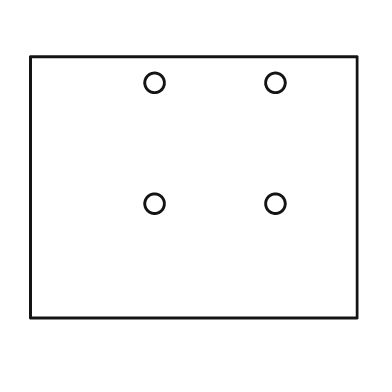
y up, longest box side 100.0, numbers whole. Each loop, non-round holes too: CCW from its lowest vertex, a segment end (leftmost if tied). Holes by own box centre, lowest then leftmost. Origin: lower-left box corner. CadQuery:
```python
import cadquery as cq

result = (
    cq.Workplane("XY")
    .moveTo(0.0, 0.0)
    .lineTo(100.0, 0.0)
    .lineTo(100.0, 80.0)
    .lineTo(0.0, 80.0)
    .close()
    .moveTo(38.0, 35.0)
    .circle(3.0)
    .moveTo(75.0, 35.0)
    .circle(3.0)
    .moveTo(38.0, 72.0)
    .circle(3.0)
    .moveTo(75.0, 72.0)
    .circle(3.0)
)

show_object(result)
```